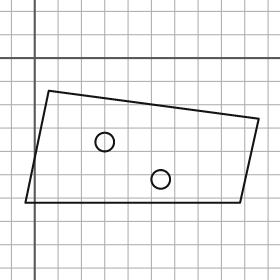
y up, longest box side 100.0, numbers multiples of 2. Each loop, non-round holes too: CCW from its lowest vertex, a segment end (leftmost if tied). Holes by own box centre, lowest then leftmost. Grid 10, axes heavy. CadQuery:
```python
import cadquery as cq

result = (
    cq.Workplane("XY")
    .moveTo(-4.0, -62.0)
    .lineTo(88.0, -62.0)
    .lineTo(96.0, -26.0)
    .lineTo(6.0, -14.0)
    .close()
    .moveTo(54.0, -52.0)
    .circle(4.0)
    .moveTo(30.0, -36.0)
    .circle(4.0)
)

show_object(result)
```